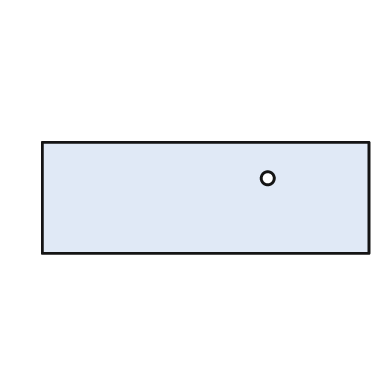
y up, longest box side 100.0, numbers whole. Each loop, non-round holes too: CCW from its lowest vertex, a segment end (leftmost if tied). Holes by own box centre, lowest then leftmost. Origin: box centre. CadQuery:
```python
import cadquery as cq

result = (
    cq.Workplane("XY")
    .moveTo(-50.0, -17.0)
    .lineTo(50.0, -17.0)
    .lineTo(50.0, 17.0)
    .lineTo(-50.0, 17.0)
    .close()
    .moveTo(19.0, 6.0)
    .circle(2.0)
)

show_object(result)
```